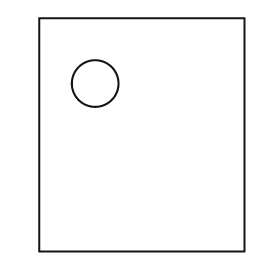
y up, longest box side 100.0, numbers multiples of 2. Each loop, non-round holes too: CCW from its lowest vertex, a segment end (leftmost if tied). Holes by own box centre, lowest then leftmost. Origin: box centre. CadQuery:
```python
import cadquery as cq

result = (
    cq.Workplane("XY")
    .moveTo(-44.0, -50.0)
    .lineTo(44.0, -50.0)
    .lineTo(44.0, 50.0)
    .lineTo(-44.0, 50.0)
    .close()
    .moveTo(-20.0, 22.0)
    .circle(10.0)
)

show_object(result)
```